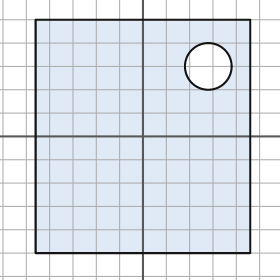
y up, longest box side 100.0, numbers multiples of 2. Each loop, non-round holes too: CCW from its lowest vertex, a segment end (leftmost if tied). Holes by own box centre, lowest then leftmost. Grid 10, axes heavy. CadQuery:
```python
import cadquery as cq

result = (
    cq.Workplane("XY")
    .moveTo(-46.0, -50.0)
    .lineTo(46.0, -50.0)
    .lineTo(46.0, 50.0)
    .lineTo(-46.0, 50.0)
    .close()
    .moveTo(28.0, 30.0)
    .circle(10.0)
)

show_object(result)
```